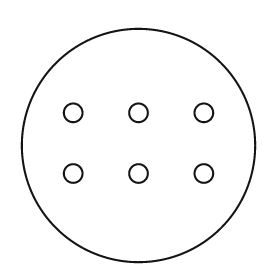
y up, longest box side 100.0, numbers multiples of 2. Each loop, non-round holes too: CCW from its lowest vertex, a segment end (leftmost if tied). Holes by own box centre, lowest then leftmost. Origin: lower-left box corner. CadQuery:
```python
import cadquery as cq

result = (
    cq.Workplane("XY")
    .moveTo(50.0, 50.0)
    .circle(50.0)
    .moveTo(22.0, 38.0)
    .circle(4.0)
    .moveTo(50.0, 38.0)
    .circle(4.0)
    .moveTo(78.0, 38.0)
    .circle(4.0)
    .moveTo(22.0, 64.0)
    .circle(4.0)
    .moveTo(50.0, 64.0)
    .circle(4.0)
    .moveTo(78.0, 64.0)
    .circle(4.0)
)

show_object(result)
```